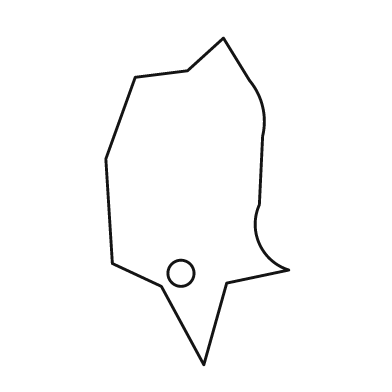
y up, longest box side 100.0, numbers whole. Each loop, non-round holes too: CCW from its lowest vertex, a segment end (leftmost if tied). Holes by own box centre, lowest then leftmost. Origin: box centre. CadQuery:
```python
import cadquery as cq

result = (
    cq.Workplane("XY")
    .moveTo(2.0, -50.0)
    .lineTo(9.0, -25.0)
    .lineTo(28.0, -21.0)
    .threePointArc((19.0, -13.0), (19.0, -1.0))
    .lineTo(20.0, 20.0)
    .threePointArc((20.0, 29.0), (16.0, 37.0))
    .lineTo(8.0, 50.0)
    .lineTo(-3.0, 40.0)
    .lineTo(-19.0, 38.0)
    .lineTo(-28.0, 13.0)
    .lineTo(-26.0, -19.0)
    .lineTo(-11.0, -26.0)
    .close()
    .moveTo(-5.0, -22.0)
    .circle(4.0)
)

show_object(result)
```